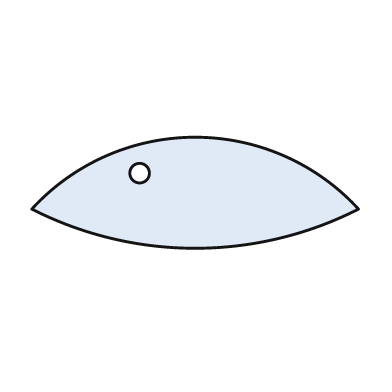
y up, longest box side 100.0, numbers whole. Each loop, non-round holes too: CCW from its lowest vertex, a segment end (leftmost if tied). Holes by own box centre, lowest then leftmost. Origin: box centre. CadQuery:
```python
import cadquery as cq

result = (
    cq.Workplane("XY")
    .moveTo(-50.0, -5.0)
    .threePointArc((0.0, -17.0), (50.0, -5.0))
    .threePointArc((0.0, 17.0), (-50.0, -5.0))
    .close()
    .moveTo(-17.0, 6.0)
    .circle(3.0)
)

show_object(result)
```